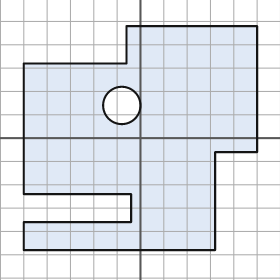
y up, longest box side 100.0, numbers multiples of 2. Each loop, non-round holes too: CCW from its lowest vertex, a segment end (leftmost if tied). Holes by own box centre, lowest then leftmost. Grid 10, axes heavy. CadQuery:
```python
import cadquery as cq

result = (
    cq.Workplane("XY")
    .moveTo(-50.0, -48.0)
    .lineTo(32.0, -48.0)
    .lineTo(32.0, -6.0)
    .lineTo(50.0, -6.0)
    .lineTo(50.0, 48.0)
    .lineTo(-6.0, 48.0)
    .lineTo(-6.0, 32.0)
    .lineTo(-50.0, 32.0)
    .lineTo(-50.0, -24.0)
    .lineTo(-4.0, -24.0)
    .lineTo(-4.0, -36.0)
    .lineTo(-50.0, -36.0)
    .close()
    .moveTo(-8.0, 14.0)
    .circle(8.0)
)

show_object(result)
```